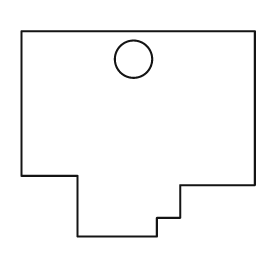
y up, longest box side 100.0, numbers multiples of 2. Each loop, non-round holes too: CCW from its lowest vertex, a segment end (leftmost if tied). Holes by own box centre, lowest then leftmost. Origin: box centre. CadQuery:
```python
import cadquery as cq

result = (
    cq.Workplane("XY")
    .moveTo(-26.0, -44.0)
    .lineTo(8.0, -44.0)
    .lineTo(8.0, -36.0)
    .lineTo(18.0, -36.0)
    .lineTo(18.0, -22.0)
    .lineTo(50.0, -22.0)
    .lineTo(50.0, 44.0)
    .lineTo(-50.0, 44.0)
    .lineTo(-50.0, -18.0)
    .lineTo(-26.0, -18.0)
    .close()
    .moveTo(-2.0, 32.0)
    .circle(8.0)
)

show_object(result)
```